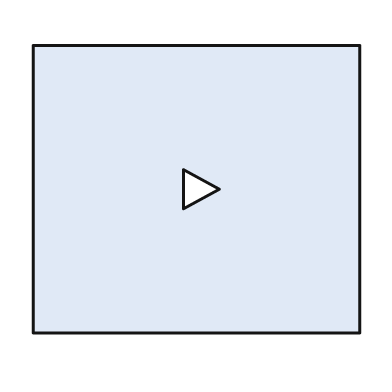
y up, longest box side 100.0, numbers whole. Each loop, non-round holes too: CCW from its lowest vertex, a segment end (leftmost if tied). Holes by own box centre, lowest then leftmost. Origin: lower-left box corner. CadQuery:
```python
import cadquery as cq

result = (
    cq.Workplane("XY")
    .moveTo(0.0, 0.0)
    .lineTo(100.0, 0.0)
    .lineTo(100.0, 88.0)
    .lineTo(0.0, 88.0)
    .close()
    .moveTo(46.0, 38.0)
    .lineTo(57.0, 44.0)
    .lineTo(46.0, 50.0)
    .close()
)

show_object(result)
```